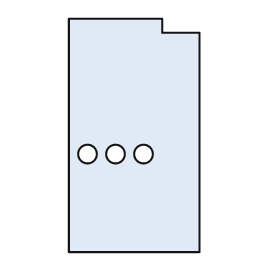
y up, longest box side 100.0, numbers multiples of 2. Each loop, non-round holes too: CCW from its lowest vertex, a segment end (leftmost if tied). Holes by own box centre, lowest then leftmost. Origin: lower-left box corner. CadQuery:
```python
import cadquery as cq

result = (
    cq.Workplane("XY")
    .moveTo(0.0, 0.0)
    .lineTo(56.0, 0.0)
    .lineTo(56.0, 94.0)
    .lineTo(40.0, 94.0)
    .lineTo(40.0, 100.0)
    .lineTo(0.0, 100.0)
    .close()
    .moveTo(8.0, 42.0)
    .circle(4.0)
    .moveTo(20.0, 42.0)
    .circle(4.0)
    .moveTo(32.0, 42.0)
    .circle(4.0)
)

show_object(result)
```